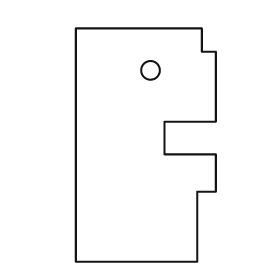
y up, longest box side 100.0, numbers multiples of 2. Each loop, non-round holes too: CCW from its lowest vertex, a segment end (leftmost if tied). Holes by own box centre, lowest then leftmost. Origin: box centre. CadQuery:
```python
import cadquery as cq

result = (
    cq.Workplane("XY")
    .moveTo(-30.0, -50.0)
    .lineTo(22.0, -50.0)
    .lineTo(22.0, -20.0)
    .lineTo(30.0, -20.0)
    .lineTo(30.0, -4.0)
    .lineTo(8.0, -4.0)
    .lineTo(8.0, 10.0)
    .lineTo(30.0, 10.0)
    .lineTo(30.0, 40.0)
    .lineTo(24.0, 40.0)
    .lineTo(24.0, 50.0)
    .lineTo(-30.0, 50.0)
    .close()
    .moveTo(2.0, 32.0)
    .circle(4.0)
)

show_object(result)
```